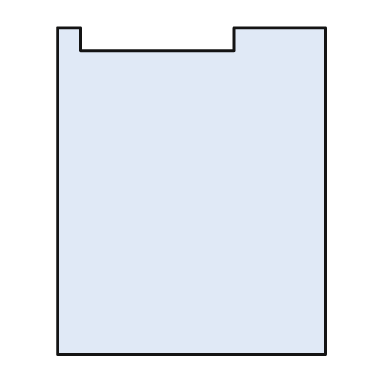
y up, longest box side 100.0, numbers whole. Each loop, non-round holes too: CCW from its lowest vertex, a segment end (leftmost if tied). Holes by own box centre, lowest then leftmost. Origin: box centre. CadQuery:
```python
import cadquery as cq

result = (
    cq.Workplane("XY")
    .moveTo(-41.0, -50.0)
    .lineTo(41.0, -50.0)
    .lineTo(41.0, 50.0)
    .lineTo(13.0, 50.0)
    .lineTo(13.0, 43.0)
    .lineTo(-34.0, 43.0)
    .lineTo(-34.0, 50.0)
    .lineTo(-41.0, 50.0)
    .close()
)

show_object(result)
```